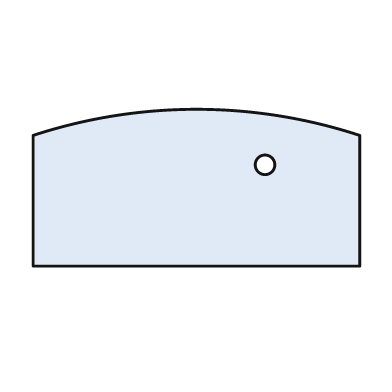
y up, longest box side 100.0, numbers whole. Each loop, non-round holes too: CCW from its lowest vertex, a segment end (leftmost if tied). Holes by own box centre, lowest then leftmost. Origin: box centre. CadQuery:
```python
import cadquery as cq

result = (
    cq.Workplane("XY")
    .moveTo(-50.0, -24.0)
    .lineTo(50.0, -24.0)
    .lineTo(50.0, 16.0)
    .threePointArc((0.0, 24.0), (-50.0, 16.0))
    .close()
    .moveTo(21.0, 7.0)
    .circle(3.0)
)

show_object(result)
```